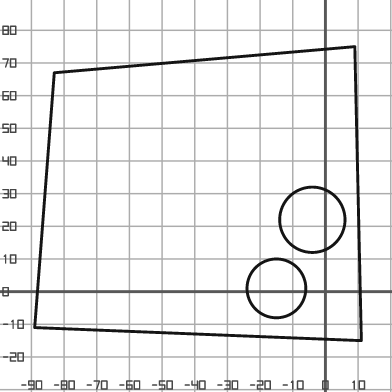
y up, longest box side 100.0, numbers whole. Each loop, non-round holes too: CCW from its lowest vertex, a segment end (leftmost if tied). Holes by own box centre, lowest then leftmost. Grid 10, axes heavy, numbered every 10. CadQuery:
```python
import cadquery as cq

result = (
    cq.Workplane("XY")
    .moveTo(11.0, -15.0)
    .lineTo(9.0, 75.0)
    .lineTo(-83.0, 67.0)
    .lineTo(-89.0, -11.0)
    .close()
    .moveTo(-15.0, 1.0)
    .circle(9.0)
    .moveTo(-4.0, 22.0)
    .circle(10.0)
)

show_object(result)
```